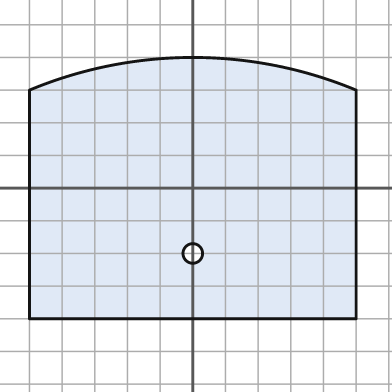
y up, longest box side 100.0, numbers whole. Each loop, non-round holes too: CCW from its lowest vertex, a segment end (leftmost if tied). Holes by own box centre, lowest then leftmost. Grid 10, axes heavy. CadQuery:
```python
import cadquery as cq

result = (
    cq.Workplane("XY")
    .moveTo(-50.0, -40.0)
    .lineTo(50.0, -40.0)
    .lineTo(50.0, 30.0)
    .threePointArc((0.0, 40.0), (-50.0, 30.0))
    .close()
    .moveTo(0.0, -20.0)
    .circle(3.0)
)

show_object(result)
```